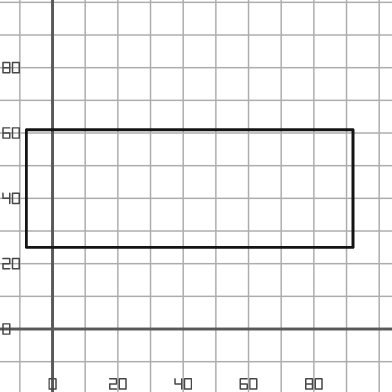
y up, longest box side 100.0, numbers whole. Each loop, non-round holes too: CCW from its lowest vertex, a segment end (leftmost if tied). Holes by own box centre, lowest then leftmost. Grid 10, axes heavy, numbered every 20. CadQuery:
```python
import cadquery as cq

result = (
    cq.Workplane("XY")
    .moveTo(-8.0, 25.0)
    .lineTo(92.0, 25.0)
    .lineTo(92.0, 61.0)
    .lineTo(-8.0, 61.0)
    .close()
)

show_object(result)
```